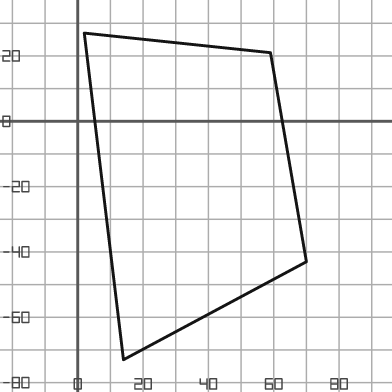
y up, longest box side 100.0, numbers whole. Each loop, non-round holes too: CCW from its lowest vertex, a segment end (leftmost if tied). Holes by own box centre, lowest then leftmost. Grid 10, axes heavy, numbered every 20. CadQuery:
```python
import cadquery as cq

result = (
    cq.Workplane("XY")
    .moveTo(14.0, -73.0)
    .lineTo(70.0, -43.0)
    .lineTo(59.0, 21.0)
    .lineTo(2.0, 27.0)
    .close()
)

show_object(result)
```